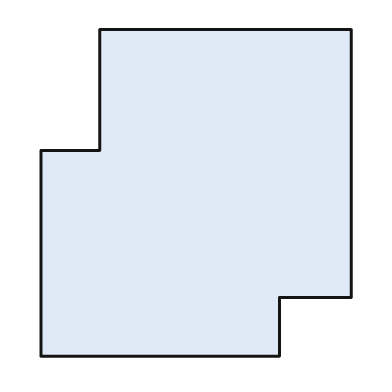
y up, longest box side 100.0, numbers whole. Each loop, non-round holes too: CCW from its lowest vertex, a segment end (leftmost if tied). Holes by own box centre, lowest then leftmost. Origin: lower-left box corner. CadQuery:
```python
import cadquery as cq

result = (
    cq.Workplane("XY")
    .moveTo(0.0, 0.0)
    .lineTo(73.0, 0.0)
    .lineTo(73.0, 18.0)
    .lineTo(95.0, 18.0)
    .lineTo(95.0, 100.0)
    .lineTo(18.0, 100.0)
    .lineTo(18.0, 63.0)
    .lineTo(0.0, 63.0)
    .close()
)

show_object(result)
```